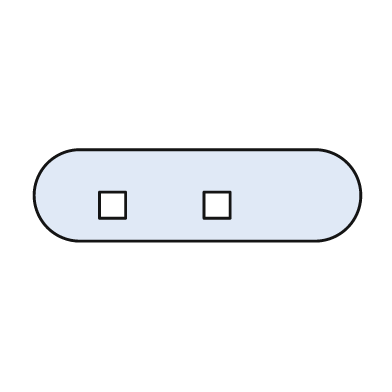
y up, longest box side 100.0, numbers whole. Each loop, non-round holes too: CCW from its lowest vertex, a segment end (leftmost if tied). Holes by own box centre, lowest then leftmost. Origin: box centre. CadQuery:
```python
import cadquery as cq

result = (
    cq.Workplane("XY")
    .moveTo(-36.0, -14.0)
    .lineTo(36.0, -14.0)
    .threePointArc((50.0, 0.0), (36.0, 14.0))
    .lineTo(-36.0, 14.0)
    .threePointArc((-50.0, 0.0), (-36.0, -14.0))
    .close()
    .moveTo(-30.0, -7.0)
    .lineTo(-22.0, -7.0)
    .lineTo(-22.0, 1.0)
    .lineTo(-30.0, 1.0)
    .close()
    .moveTo(2.0, -7.0)
    .lineTo(10.0, -7.0)
    .lineTo(10.0, 1.0)
    .lineTo(2.0, 1.0)
    .close()
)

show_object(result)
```